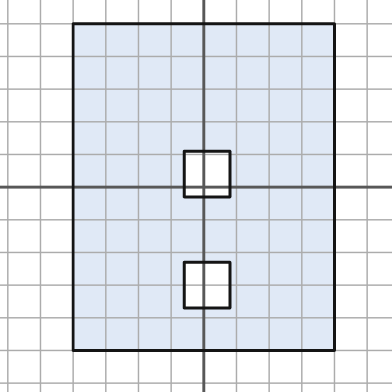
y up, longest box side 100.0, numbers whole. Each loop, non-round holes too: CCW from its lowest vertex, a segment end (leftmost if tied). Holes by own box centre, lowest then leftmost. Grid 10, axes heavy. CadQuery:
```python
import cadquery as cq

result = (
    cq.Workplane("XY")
    .moveTo(-40.0, -50.0)
    .lineTo(40.0, -50.0)
    .lineTo(40.0, 50.0)
    .lineTo(-40.0, 50.0)
    .close()
    .moveTo(-6.0, -37.0)
    .lineTo(8.0, -37.0)
    .lineTo(8.0, -23.0)
    .lineTo(-6.0, -23.0)
    .close()
    .moveTo(-6.0, -3.0)
    .lineTo(8.0, -3.0)
    .lineTo(8.0, 11.0)
    .lineTo(-6.0, 11.0)
    .close()
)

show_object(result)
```